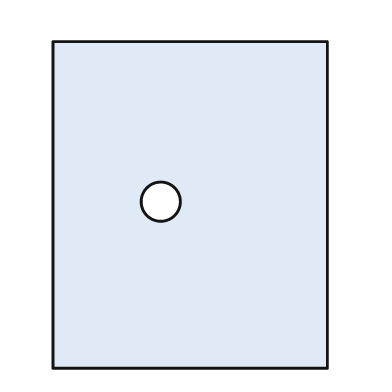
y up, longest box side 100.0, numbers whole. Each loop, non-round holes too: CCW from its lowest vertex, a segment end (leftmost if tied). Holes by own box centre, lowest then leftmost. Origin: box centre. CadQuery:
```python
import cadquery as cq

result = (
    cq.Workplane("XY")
    .moveTo(-42.0, -50.0)
    .lineTo(42.0, -50.0)
    .lineTo(42.0, 50.0)
    .lineTo(-42.0, 50.0)
    .close()
    .moveTo(-9.0, 1.0)
    .circle(6.0)
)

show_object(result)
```